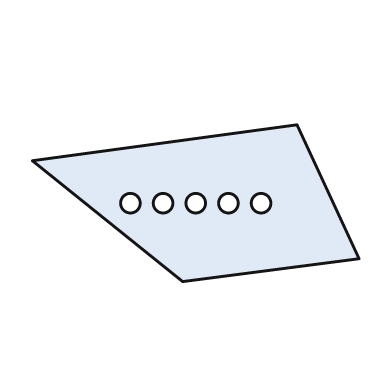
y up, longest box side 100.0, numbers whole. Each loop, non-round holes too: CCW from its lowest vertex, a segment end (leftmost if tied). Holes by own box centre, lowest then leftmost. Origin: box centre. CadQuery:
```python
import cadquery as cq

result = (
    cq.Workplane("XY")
    .moveTo(-4.0, -24.0)
    .lineTo(50.0, -17.0)
    .lineTo(31.0, 24.0)
    .lineTo(-50.0, 13.0)
    .close()
    .moveTo(-20.0, 0.0)
    .circle(3.0)
    .moveTo(-10.0, 0.0)
    .circle(3.0)
    .moveTo(0.0, 0.0)
    .circle(3.0)
    .moveTo(10.0, 0.0)
    .circle(3.0)
    .moveTo(20.0, 0.0)
    .circle(3.0)
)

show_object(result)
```